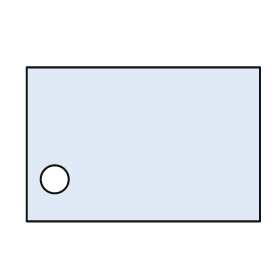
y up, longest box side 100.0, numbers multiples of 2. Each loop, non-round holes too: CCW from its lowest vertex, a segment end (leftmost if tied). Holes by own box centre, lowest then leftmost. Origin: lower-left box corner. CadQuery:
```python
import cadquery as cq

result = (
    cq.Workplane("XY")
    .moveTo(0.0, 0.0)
    .lineTo(100.0, 0.0)
    .lineTo(100.0, 66.0)
    .lineTo(0.0, 66.0)
    .close()
    .moveTo(12.0, 18.0)
    .circle(6.0)
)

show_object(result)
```